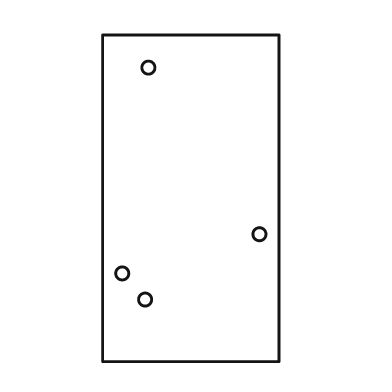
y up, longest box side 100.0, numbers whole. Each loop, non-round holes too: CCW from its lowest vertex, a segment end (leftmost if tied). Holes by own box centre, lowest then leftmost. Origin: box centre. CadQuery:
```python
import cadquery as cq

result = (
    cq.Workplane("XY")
    .moveTo(-27.0, -50.0)
    .lineTo(27.0, -50.0)
    .lineTo(27.0, 50.0)
    .lineTo(-27.0, 50.0)
    .close()
    .moveTo(-14.0, -31.0)
    .circle(2.0)
    .moveTo(-21.0, -23.0)
    .circle(2.0)
    .moveTo(21.0, -11.0)
    .circle(2.0)
    .moveTo(-13.0, 40.0)
    .circle(2.0)
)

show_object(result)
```